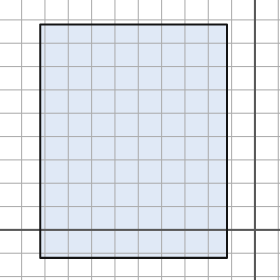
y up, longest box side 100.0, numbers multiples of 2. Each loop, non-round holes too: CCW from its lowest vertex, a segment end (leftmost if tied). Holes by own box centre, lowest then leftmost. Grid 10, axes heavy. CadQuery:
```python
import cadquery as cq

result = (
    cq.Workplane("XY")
    .moveTo(-92.0, -12.0)
    .lineTo(-12.0, -12.0)
    .lineTo(-12.0, 88.0)
    .lineTo(-92.0, 88.0)
    .close()
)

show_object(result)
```